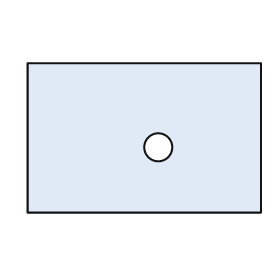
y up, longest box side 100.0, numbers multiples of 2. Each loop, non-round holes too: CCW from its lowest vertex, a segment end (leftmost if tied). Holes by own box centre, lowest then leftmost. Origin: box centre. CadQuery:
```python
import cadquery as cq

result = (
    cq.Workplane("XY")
    .moveTo(-50.0, -32.0)
    .lineTo(50.0, -32.0)
    .lineTo(50.0, 32.0)
    .lineTo(-50.0, 32.0)
    .close()
    .moveTo(6.0, -4.0)
    .circle(6.0)
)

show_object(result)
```